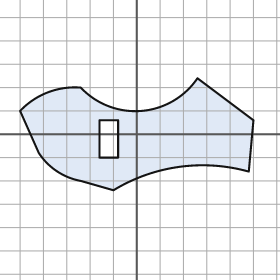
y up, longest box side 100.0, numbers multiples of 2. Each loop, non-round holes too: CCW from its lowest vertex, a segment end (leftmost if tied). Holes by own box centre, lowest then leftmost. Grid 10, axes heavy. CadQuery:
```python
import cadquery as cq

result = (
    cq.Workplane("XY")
    .moveTo(-10.0, -24.0)
    .threePointArc((18.0, -14.0), (48.0, -16.0))
    .lineTo(50.0, 6.0)
    .lineTo(26.0, 24.0)
    .threePointArc((2.0, 10.0), (-24.0, 20.0))
    .threePointArc((-38.0, 18.0), (-50.0, 10.0))
    .lineTo(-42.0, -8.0)
    .threePointArc((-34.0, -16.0), (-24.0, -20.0))
    .close()
    .moveTo(-16.0, -10.0)
    .lineTo(-8.0, -10.0)
    .lineTo(-8.0, 6.0)
    .lineTo(-16.0, 6.0)
    .close()
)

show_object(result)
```